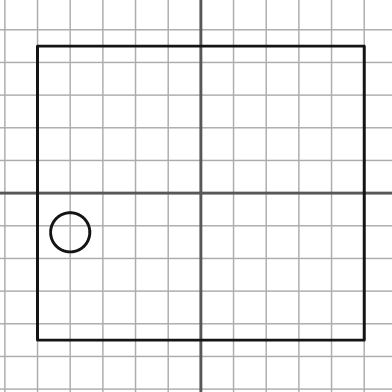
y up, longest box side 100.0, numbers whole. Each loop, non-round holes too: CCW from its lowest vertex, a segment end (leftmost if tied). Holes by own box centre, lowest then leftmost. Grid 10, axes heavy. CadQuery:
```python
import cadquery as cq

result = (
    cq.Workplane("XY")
    .moveTo(-50.0, -45.0)
    .lineTo(50.0, -45.0)
    .lineTo(50.0, 45.0)
    .lineTo(-50.0, 45.0)
    .close()
    .moveTo(-40.0, -12.0)
    .circle(6.0)
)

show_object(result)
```